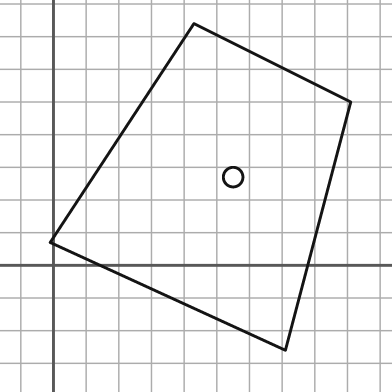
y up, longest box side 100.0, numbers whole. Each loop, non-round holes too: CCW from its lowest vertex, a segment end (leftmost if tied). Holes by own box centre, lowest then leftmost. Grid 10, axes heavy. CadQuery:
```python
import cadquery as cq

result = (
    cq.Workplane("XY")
    .moveTo(71.0, -26.0)
    .lineTo(91.0, 50.0)
    .lineTo(43.0, 74.0)
    .lineTo(-1.0, 7.0)
    .close()
    .moveTo(55.0, 27.0)
    .circle(3.0)
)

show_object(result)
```